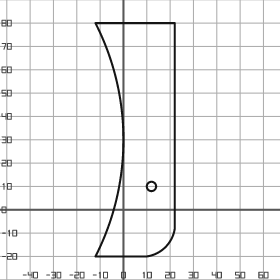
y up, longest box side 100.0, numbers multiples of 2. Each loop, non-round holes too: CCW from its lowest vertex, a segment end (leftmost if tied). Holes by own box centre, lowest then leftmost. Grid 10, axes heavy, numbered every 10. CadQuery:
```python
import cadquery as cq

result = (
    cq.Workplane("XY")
    .moveTo(-12.0, -20.0)
    .lineTo(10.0, -20.0)
    .threePointArc((18.0, -16.0), (22.0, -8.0))
    .lineTo(22.0, 80.0)
    .lineTo(-12.0, 80.0)
    .threePointArc((0.0, 30.0), (-12.0, -20.0))
    .close()
    .moveTo(12.0, 10.0)
    .circle(2.0)
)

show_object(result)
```